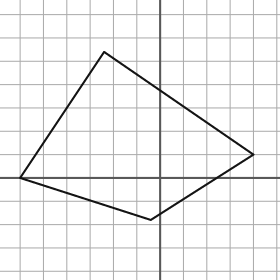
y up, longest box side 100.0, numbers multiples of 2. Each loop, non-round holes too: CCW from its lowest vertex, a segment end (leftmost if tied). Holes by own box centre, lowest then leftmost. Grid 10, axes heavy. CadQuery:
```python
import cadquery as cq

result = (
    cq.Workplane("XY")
    .moveTo(-4.0, -18.0)
    .lineTo(40.0, 10.0)
    .lineTo(-24.0, 54.0)
    .lineTo(-60.0, 0.0)
    .close()
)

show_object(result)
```